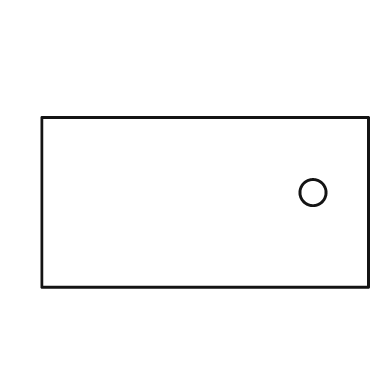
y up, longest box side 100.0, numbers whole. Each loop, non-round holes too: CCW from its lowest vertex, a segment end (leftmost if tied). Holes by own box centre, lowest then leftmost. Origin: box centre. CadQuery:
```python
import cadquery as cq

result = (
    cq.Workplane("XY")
    .moveTo(-50.0, -26.0)
    .lineTo(50.0, -26.0)
    .lineTo(50.0, 26.0)
    .lineTo(-50.0, 26.0)
    .close()
    .moveTo(33.0, 3.0)
    .circle(4.0)
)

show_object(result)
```